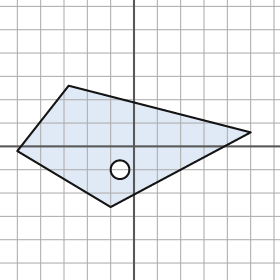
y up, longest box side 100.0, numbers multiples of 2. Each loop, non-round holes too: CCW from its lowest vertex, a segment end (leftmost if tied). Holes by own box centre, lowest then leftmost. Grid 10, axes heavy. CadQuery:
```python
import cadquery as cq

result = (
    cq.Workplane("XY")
    .moveTo(-10.0, -26.0)
    .lineTo(50.0, 6.0)
    .lineTo(-28.0, 26.0)
    .lineTo(-50.0, -2.0)
    .close()
    .moveTo(-6.0, -10.0)
    .circle(4.0)
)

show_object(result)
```